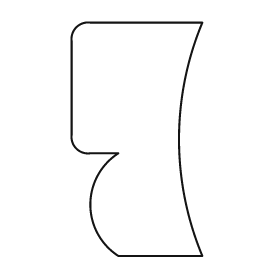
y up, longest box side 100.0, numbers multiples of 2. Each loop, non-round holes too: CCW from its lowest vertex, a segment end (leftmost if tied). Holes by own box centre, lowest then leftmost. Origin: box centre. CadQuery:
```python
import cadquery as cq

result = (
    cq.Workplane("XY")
    .moveTo(-8.0, -50.0)
    .lineTo(28.0, -50.0)
    .threePointArc((18.0, 0.0), (28.0, 50.0))
    .lineTo(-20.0, 50.0)
    .threePointArc((-26.0, 48.0), (-28.0, 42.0))
    .lineTo(-28.0, 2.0)
    .threePointArc((-26.0, -4.0), (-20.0, -6.0))
    .lineTo(-8.0, -6.0)
    .threePointArc((-20.0, -28.0), (-8.0, -50.0))
    .close()
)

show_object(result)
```